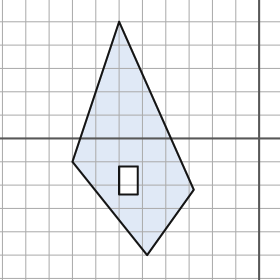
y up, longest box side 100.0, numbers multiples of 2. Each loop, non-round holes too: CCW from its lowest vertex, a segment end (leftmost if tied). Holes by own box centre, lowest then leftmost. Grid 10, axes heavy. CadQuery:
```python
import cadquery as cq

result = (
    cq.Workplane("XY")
    .moveTo(-48.0, -50.0)
    .lineTo(-28.0, -22.0)
    .lineTo(-60.0, 50.0)
    .lineTo(-80.0, -10.0)
    .close()
    .moveTo(-60.0, -24.0)
    .lineTo(-52.0, -24.0)
    .lineTo(-52.0, -12.0)
    .lineTo(-60.0, -12.0)
    .close()
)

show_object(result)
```